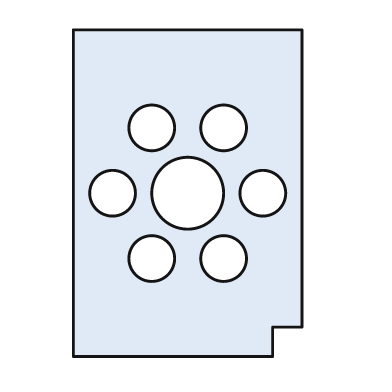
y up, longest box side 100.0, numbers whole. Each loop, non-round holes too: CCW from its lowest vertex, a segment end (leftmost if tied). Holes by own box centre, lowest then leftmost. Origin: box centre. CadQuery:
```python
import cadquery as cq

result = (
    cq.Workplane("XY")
    .moveTo(-35.0, -50.0)
    .lineTo(26.0, -50.0)
    .lineTo(26.0, -41.0)
    .lineTo(35.0, -41.0)
    .lineTo(35.0, 50.0)
    .lineTo(-35.0, 50.0)
    .close()
    .moveTo(-11.0, -20.0)
    .circle(7.0)
    .moveTo(11.0, -20.0)
    .circle(7.0)
    .moveTo(-23.0, 0.0)
    .circle(7.0)
    .moveTo(0.0, 0.0)
    .circle(11.0)
    .moveTo(23.0, 0.0)
    .circle(7.0)
    .moveTo(-11.0, 20.0)
    .circle(7.0)
    .moveTo(11.0, 20.0)
    .circle(7.0)
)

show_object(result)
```